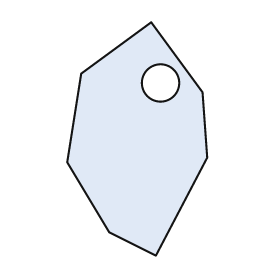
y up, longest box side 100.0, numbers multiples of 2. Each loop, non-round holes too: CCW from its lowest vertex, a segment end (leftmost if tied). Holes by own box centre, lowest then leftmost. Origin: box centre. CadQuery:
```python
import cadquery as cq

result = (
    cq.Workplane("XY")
    .moveTo(8.0, -50.0)
    .lineTo(30.0, -8.0)
    .lineTo(28.0, 20.0)
    .lineTo(6.0, 50.0)
    .lineTo(-24.0, 28.0)
    .lineTo(-30.0, -10.0)
    .lineTo(-12.0, -40.0)
    .close()
    .moveTo(10.0, 24.0)
    .circle(8.0)
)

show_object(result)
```